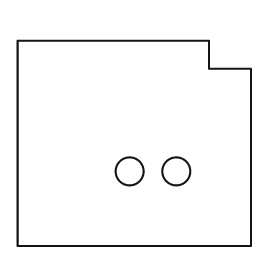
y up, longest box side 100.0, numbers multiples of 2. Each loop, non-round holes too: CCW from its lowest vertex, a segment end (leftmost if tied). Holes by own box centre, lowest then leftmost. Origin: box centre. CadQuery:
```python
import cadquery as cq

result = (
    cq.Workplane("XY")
    .moveTo(-50.0, -44.0)
    .lineTo(50.0, -44.0)
    .lineTo(50.0, 32.0)
    .lineTo(32.0, 32.0)
    .lineTo(32.0, 44.0)
    .lineTo(-50.0, 44.0)
    .close()
    .moveTo(-2.0, -12.0)
    .circle(6.0)
    .moveTo(18.0, -12.0)
    .circle(6.0)
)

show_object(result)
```